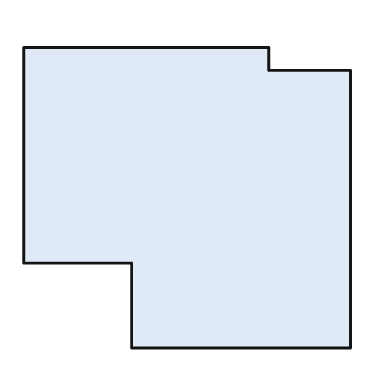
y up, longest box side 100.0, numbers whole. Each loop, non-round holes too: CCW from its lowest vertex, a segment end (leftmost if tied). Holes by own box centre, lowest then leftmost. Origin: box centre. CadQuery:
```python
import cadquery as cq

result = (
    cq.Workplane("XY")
    .moveTo(-17.0, -46.0)
    .lineTo(50.0, -46.0)
    .lineTo(50.0, 39.0)
    .lineTo(25.0, 39.0)
    .lineTo(25.0, 46.0)
    .lineTo(-50.0, 46.0)
    .lineTo(-50.0, -20.0)
    .lineTo(-17.0, -20.0)
    .close()
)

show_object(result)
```